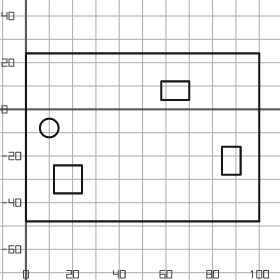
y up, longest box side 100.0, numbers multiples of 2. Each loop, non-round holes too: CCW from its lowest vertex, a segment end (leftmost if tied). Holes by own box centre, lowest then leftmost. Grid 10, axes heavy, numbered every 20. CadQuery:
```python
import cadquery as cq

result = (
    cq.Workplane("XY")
    .moveTo(0.0, -48.0)
    .lineTo(100.0, -48.0)
    .lineTo(100.0, 24.0)
    .lineTo(0.0, 24.0)
    .close()
    .moveTo(12.0, -36.0)
    .lineTo(24.0, -36.0)
    .lineTo(24.0, -24.0)
    .lineTo(12.0, -24.0)
    .close()
    .moveTo(84.0, -28.0)
    .lineTo(92.0, -28.0)
    .lineTo(92.0, -16.0)
    .lineTo(84.0, -16.0)
    .close()
    .moveTo(10.0, -8.0)
    .circle(4.0)
    .moveTo(58.0, 4.0)
    .lineTo(70.0, 4.0)
    .lineTo(70.0, 12.0)
    .lineTo(58.0, 12.0)
    .close()
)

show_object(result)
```